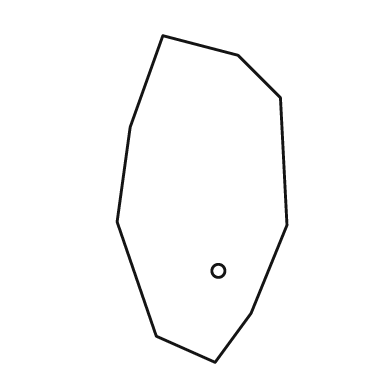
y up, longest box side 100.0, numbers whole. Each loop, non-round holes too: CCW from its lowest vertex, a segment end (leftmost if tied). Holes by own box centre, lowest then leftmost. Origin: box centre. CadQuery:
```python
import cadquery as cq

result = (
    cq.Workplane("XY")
    .moveTo(4.0, -50.0)
    .lineTo(15.0, -35.0)
    .lineTo(26.0, -8.0)
    .lineTo(24.0, 31.0)
    .lineTo(11.0, 44.0)
    .lineTo(-12.0, 50.0)
    .lineTo(-22.0, 22.0)
    .lineTo(-26.0, -7.0)
    .lineTo(-14.0, -42.0)
    .close()
    .moveTo(5.0, -22.0)
    .circle(2.0)
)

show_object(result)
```